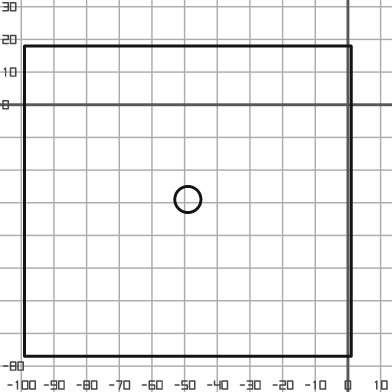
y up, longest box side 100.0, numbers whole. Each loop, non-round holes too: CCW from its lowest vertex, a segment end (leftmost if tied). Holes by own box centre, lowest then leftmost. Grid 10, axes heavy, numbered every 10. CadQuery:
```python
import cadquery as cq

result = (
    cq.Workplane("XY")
    .moveTo(-99.0, -77.0)
    .lineTo(1.0, -77.0)
    .lineTo(1.0, 18.0)
    .lineTo(-99.0, 18.0)
    .close()
    .moveTo(-49.0, -29.0)
    .circle(4.0)
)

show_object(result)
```